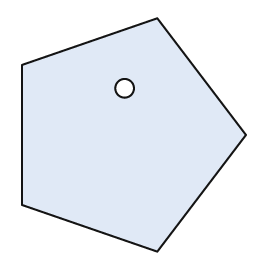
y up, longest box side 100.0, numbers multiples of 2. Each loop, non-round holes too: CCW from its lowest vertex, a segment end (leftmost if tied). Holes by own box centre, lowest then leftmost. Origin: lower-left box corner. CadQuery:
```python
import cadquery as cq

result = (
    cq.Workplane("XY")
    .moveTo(58.0, 0.0)
    .lineTo(96.0, 50.0)
    .lineTo(58.0, 100.0)
    .lineTo(0.0, 80.0)
    .lineTo(0.0, 20.0)
    .close()
    .moveTo(44.0, 70.0)
    .circle(4.0)
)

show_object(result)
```